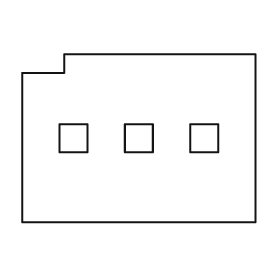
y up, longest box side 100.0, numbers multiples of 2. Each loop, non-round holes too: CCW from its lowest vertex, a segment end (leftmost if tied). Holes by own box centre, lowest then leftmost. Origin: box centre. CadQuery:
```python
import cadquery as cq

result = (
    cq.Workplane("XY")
    .moveTo(-50.0, -36.0)
    .lineTo(50.0, -36.0)
    .lineTo(50.0, 36.0)
    .lineTo(-32.0, 36.0)
    .lineTo(-32.0, 28.0)
    .lineTo(-50.0, 28.0)
    .close()
    .moveTo(-34.0, -6.0)
    .lineTo(-22.0, -6.0)
    .lineTo(-22.0, 6.0)
    .lineTo(-34.0, 6.0)
    .close()
    .moveTo(-6.0, -6.0)
    .lineTo(6.0, -6.0)
    .lineTo(6.0, 6.0)
    .lineTo(-6.0, 6.0)
    .close()
    .moveTo(22.0, -6.0)
    .lineTo(34.0, -6.0)
    .lineTo(34.0, 6.0)
    .lineTo(22.0, 6.0)
    .close()
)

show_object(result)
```